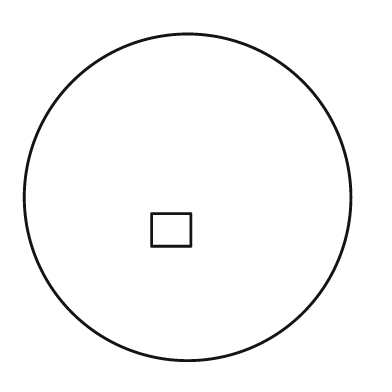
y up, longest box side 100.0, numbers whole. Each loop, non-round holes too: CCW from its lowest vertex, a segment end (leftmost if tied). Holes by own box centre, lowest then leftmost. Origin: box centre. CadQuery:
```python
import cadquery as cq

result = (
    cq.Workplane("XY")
    .moveTo(0.0, 0.0)
    .circle(50.0)
    .moveTo(-11.0, -15.0)
    .lineTo(1.0, -15.0)
    .lineTo(1.0, -5.0)
    .lineTo(-11.0, -5.0)
    .close()
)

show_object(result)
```